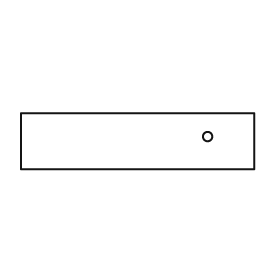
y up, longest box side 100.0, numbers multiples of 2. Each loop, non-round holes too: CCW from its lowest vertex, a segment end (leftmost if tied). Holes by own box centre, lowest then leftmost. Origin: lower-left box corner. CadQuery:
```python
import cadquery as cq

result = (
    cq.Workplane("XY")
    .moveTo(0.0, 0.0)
    .lineTo(100.0, 0.0)
    .lineTo(100.0, 24.0)
    .lineTo(0.0, 24.0)
    .close()
    .moveTo(80.0, 14.0)
    .circle(2.0)
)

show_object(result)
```